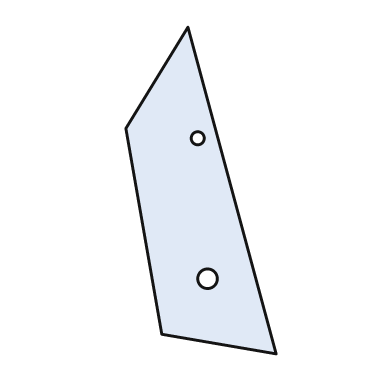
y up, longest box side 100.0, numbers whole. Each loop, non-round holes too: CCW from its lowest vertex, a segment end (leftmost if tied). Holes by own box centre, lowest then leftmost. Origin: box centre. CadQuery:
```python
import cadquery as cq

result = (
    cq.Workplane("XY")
    .moveTo(23.0, -50.0)
    .lineTo(-4.0, 50.0)
    .lineTo(-23.0, 19.0)
    .lineTo(-12.0, -44.0)
    .close()
    .moveTo(2.0, -27.0)
    .circle(3.0)
    .moveTo(-1.0, 16.0)
    .circle(2.0)
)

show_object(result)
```